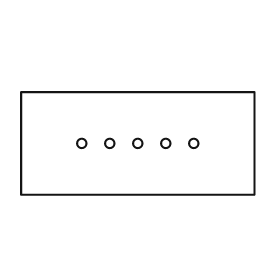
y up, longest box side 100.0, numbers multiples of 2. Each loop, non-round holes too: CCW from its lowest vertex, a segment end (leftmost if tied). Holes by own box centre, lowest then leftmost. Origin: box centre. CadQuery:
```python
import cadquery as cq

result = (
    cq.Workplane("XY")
    .moveTo(-50.0, -22.0)
    .lineTo(50.0, -22.0)
    .lineTo(50.0, 22.0)
    .lineTo(-50.0, 22.0)
    .close()
    .moveTo(-24.0, 0.0)
    .circle(2.0)
    .moveTo(-12.0, 0.0)
    .circle(2.0)
    .moveTo(0.0, 0.0)
    .circle(2.0)
    .moveTo(12.0, 0.0)
    .circle(2.0)
    .moveTo(24.0, 0.0)
    .circle(2.0)
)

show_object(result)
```